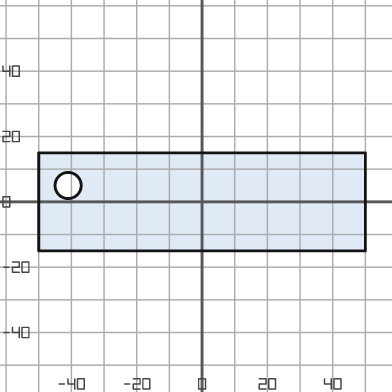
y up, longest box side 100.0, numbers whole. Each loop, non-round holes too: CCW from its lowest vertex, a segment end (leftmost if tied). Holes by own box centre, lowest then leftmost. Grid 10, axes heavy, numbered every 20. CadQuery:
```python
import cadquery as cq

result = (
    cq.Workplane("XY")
    .moveTo(-50.0, -15.0)
    .lineTo(50.0, -15.0)
    .lineTo(50.0, 15.0)
    .lineTo(-50.0, 15.0)
    .close()
    .moveTo(-41.0, 5.0)
    .circle(4.0)
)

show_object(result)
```